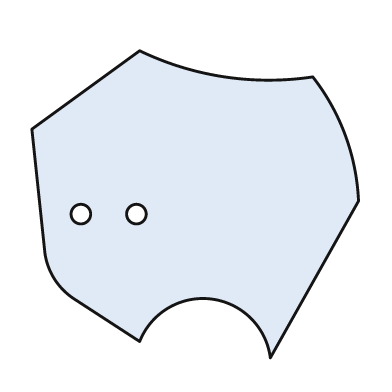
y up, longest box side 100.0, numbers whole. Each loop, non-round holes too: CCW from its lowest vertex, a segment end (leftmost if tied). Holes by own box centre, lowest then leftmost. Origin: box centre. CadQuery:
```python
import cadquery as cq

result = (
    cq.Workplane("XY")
    .moveTo(23.0, -47.0)
    .lineTo(50.0, 1.0)
    .threePointArc((46.0, 21.0), (36.0, 39.0))
    .threePointArc((9.0, 39.0), (-17.0, 47.0))
    .lineTo(-50.0, 23.0)
    .lineTo(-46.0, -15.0)
    .threePointArc((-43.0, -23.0), (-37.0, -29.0))
    .lineTo(-17.0, -42.0)
    .threePointArc((5.0, -29.0), (23.0, -47.0))
    .close()
    .moveTo(-35.0, -3.0)
    .circle(3.0)
    .moveTo(-18.0, -3.0)
    .circle(3.0)
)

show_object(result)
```